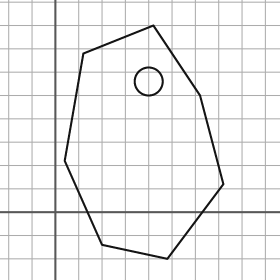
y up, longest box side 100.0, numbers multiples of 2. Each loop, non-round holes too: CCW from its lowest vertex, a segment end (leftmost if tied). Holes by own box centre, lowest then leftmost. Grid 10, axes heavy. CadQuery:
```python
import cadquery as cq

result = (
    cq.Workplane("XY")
    .moveTo(48.0, -20.0)
    .lineTo(72.0, 12.0)
    .lineTo(62.0, 50.0)
    .lineTo(42.0, 80.0)
    .lineTo(12.0, 68.0)
    .lineTo(4.0, 22.0)
    .lineTo(20.0, -14.0)
    .close()
    .moveTo(40.0, 56.0)
    .circle(6.0)
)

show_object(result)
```